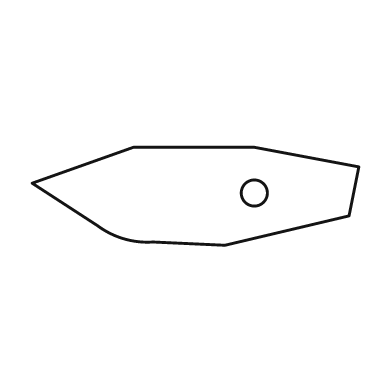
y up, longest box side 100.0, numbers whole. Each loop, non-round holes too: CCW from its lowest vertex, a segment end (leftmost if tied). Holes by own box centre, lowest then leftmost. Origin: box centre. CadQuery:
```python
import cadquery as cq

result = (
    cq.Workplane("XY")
    .moveTo(9.0, -15.0)
    .lineTo(47.0, -6.0)
    .lineTo(50.0, 9.0)
    .lineTo(18.0, 15.0)
    .lineTo(-19.0, 15.0)
    .lineTo(-50.0, 4.0)
    .lineTo(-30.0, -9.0)
    .threePointArc((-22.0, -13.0), (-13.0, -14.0))
    .close()
    .moveTo(18.0, 1.0)
    .circle(4.0)
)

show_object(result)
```